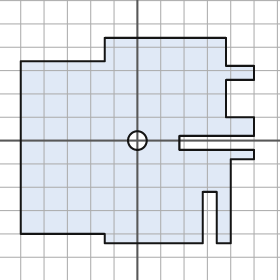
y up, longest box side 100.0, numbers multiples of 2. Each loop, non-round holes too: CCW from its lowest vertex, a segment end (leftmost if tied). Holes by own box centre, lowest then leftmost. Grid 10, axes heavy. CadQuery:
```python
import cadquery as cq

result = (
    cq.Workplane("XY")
    .moveTo(-14.0, -44.0)
    .lineTo(28.0, -44.0)
    .lineTo(28.0, -22.0)
    .lineTo(34.0, -22.0)
    .lineTo(34.0, -44.0)
    .lineTo(40.0, -44.0)
    .lineTo(40.0, -8.0)
    .lineTo(50.0, -8.0)
    .lineTo(50.0, -4.0)
    .lineTo(18.0, -4.0)
    .lineTo(18.0, 2.0)
    .lineTo(50.0, 2.0)
    .lineTo(50.0, 10.0)
    .lineTo(38.0, 10.0)
    .lineTo(38.0, 26.0)
    .lineTo(50.0, 26.0)
    .lineTo(50.0, 32.0)
    .lineTo(38.0, 32.0)
    .lineTo(38.0, 44.0)
    .lineTo(-14.0, 44.0)
    .lineTo(-14.0, 34.0)
    .lineTo(-50.0, 34.0)
    .lineTo(-50.0, -40.0)
    .lineTo(-14.0, -40.0)
    .close()
    .moveTo(0.0, 0.0)
    .circle(4.0)
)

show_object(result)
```